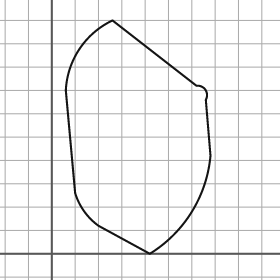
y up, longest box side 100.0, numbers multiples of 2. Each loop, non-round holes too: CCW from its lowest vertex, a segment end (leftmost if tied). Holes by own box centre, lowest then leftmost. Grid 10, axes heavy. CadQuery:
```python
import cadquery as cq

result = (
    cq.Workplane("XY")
    .moveTo(42.0, 0.0)
    .threePointArc((60.0, 18.0), (68.0, 42.0))
    .lineTo(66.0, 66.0)
    .threePointArc((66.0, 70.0), (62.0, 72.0))
    .lineTo(26.0, 100.0)
    .threePointArc((12.0, 88.0), (6.0, 70.0))
    .lineTo(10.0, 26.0)
    .threePointArc((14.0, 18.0), (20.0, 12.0))
    .close()
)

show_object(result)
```